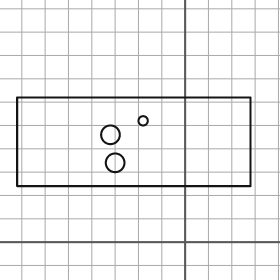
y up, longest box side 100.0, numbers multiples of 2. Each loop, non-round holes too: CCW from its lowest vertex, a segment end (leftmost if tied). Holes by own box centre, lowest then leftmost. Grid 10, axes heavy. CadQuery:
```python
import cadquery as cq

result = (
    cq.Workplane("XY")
    .moveTo(-72.0, 24.0)
    .lineTo(28.0, 24.0)
    .lineTo(28.0, 62.0)
    .lineTo(-72.0, 62.0)
    .close()
    .moveTo(-30.0, 34.0)
    .circle(4.0)
    .moveTo(-32.0, 46.0)
    .circle(4.0)
    .moveTo(-18.0, 52.0)
    .circle(2.0)
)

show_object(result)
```